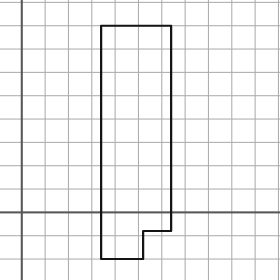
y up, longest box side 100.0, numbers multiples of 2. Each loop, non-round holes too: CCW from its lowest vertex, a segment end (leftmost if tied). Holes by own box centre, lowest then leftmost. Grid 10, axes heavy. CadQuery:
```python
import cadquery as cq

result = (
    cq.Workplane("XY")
    .moveTo(34.0, -20.0)
    .lineTo(52.0, -20.0)
    .lineTo(52.0, -8.0)
    .lineTo(64.0, -8.0)
    .lineTo(64.0, 80.0)
    .lineTo(34.0, 80.0)
    .close()
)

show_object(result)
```